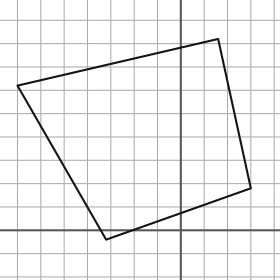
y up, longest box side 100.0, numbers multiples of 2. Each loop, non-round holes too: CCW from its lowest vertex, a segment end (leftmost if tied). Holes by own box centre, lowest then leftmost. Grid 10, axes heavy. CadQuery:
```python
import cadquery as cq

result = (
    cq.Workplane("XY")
    .moveTo(-32.0, -4.0)
    .lineTo(30.0, 18.0)
    .lineTo(16.0, 82.0)
    .lineTo(-70.0, 62.0)
    .close()
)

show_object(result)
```